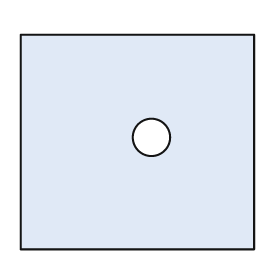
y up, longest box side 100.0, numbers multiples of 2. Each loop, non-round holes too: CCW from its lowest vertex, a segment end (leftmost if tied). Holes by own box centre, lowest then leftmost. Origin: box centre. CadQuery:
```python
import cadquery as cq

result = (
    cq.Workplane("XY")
    .moveTo(-50.0, -46.0)
    .lineTo(50.0, -46.0)
    .lineTo(50.0, 46.0)
    .lineTo(-50.0, 46.0)
    .close()
    .moveTo(6.0, 2.0)
    .circle(8.0)
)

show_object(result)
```